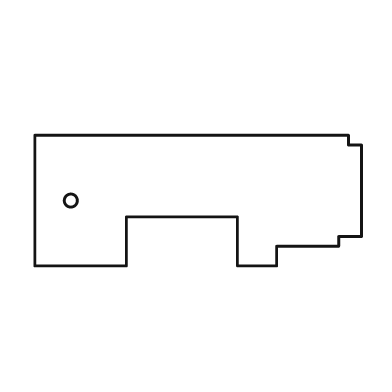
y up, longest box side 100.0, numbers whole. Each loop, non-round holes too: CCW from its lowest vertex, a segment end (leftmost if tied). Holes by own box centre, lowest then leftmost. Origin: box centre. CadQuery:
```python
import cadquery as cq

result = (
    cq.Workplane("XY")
    .moveTo(-50.0, -20.0)
    .lineTo(-22.0, -20.0)
    .lineTo(-22.0, -5.0)
    .lineTo(12.0, -5.0)
    .lineTo(12.0, -20.0)
    .lineTo(24.0, -20.0)
    .lineTo(24.0, -14.0)
    .lineTo(43.0, -14.0)
    .lineTo(43.0, -11.0)
    .lineTo(50.0, -11.0)
    .lineTo(50.0, 17.0)
    .lineTo(46.0, 17.0)
    .lineTo(46.0, 20.0)
    .lineTo(-50.0, 20.0)
    .close()
    .moveTo(-39.0, 0.0)
    .circle(2.0)
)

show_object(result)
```